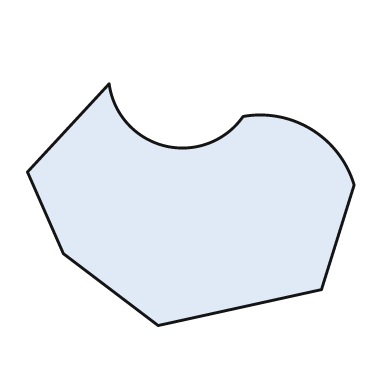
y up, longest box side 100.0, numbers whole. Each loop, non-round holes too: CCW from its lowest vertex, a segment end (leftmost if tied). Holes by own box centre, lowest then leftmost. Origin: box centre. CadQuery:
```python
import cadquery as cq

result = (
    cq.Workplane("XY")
    .moveTo(-10.0, -37.0)
    .lineTo(40.0, -26.0)
    .lineTo(50.0, 6.0)
    .threePointArc((37.0, 23.0), (16.0, 27.0))
    .threePointArc((-8.0, 18.0), (-25.0, 37.0))
    .lineTo(-50.0, 10.0)
    .lineTo(-39.0, -15.0)
    .close()
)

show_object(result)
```